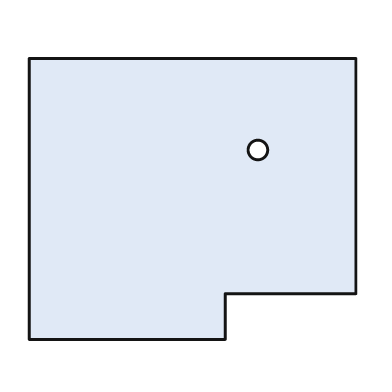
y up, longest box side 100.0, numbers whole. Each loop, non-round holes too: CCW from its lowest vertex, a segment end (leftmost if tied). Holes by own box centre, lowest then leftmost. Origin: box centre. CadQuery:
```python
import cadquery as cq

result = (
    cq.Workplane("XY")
    .moveTo(-50.0, -43.0)
    .lineTo(10.0, -43.0)
    .lineTo(10.0, -29.0)
    .lineTo(50.0, -29.0)
    .lineTo(50.0, 43.0)
    .lineTo(-50.0, 43.0)
    .close()
    .moveTo(20.0, 15.0)
    .circle(3.0)
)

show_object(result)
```